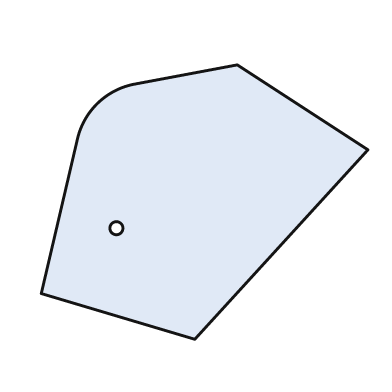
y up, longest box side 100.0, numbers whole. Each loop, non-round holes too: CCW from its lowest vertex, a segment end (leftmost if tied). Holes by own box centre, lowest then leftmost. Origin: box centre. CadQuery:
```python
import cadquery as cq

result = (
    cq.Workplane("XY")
    .moveTo(-3.0, -42.0)
    .lineTo(50.0, 16.0)
    .lineTo(10.0, 42.0)
    .lineTo(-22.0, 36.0)
    .threePointArc((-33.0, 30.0), (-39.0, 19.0))
    .lineTo(-50.0, -28.0)
    .close()
    .moveTo(-27.0, -8.0)
    .circle(2.0)
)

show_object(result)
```